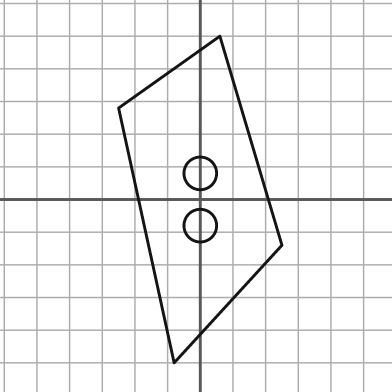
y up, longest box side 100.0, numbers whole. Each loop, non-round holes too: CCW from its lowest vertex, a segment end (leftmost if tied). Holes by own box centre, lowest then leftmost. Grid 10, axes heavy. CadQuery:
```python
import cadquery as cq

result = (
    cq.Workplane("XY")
    .moveTo(-8.0, -50.0)
    .lineTo(25.0, -14.0)
    .lineTo(6.0, 50.0)
    .lineTo(-25.0, 28.0)
    .close()
    .moveTo(0.0, -8.0)
    .circle(5.0)
    .moveTo(0.0, 8.0)
    .circle(5.0)
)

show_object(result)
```